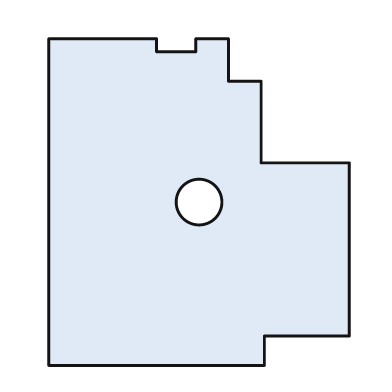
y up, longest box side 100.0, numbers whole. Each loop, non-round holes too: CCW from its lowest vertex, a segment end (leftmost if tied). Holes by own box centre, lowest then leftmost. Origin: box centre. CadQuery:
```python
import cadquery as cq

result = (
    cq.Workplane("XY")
    .moveTo(-46.0, -50.0)
    .lineTo(20.0, -50.0)
    .lineTo(20.0, -41.0)
    .lineTo(46.0, -41.0)
    .lineTo(46.0, 12.0)
    .lineTo(19.0, 12.0)
    .lineTo(19.0, 37.0)
    .lineTo(9.0, 37.0)
    .lineTo(9.0, 50.0)
    .lineTo(-1.0, 50.0)
    .lineTo(-1.0, 46.0)
    .lineTo(-13.0, 46.0)
    .lineTo(-13.0, 50.0)
    .lineTo(-46.0, 50.0)
    .close()
    .moveTo(0.0, 0.0)
    .circle(7.0)
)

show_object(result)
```